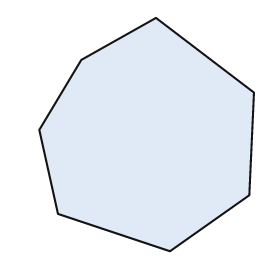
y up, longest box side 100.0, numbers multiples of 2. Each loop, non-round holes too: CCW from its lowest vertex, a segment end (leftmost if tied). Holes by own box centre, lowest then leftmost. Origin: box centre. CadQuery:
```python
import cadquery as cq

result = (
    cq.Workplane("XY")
    .moveTo(10.0, -50.0)
    .lineTo(44.0, -26.0)
    .lineTo(46.0, 18.0)
    .lineTo(4.0, 50.0)
    .lineTo(-28.0, 32.0)
    .lineTo(-46.0, 2.0)
    .lineTo(-38.0, -34.0)
    .close()
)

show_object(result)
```